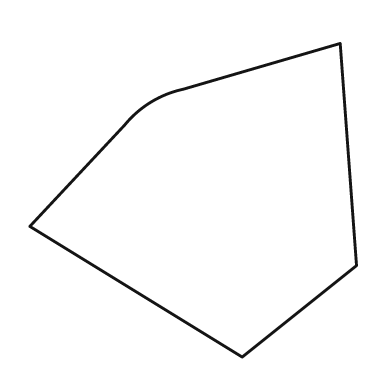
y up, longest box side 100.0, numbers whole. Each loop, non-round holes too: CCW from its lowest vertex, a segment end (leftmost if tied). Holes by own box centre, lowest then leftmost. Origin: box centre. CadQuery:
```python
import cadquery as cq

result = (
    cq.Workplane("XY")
    .moveTo(15.0, -48.0)
    .lineTo(50.0, -20.0)
    .lineTo(45.0, 48.0)
    .lineTo(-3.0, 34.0)
    .threePointArc((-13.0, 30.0), (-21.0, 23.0))
    .lineTo(-50.0, -8.0)
    .close()
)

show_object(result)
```